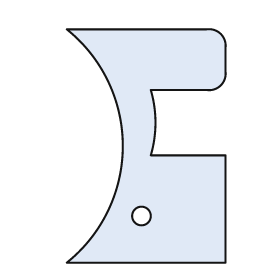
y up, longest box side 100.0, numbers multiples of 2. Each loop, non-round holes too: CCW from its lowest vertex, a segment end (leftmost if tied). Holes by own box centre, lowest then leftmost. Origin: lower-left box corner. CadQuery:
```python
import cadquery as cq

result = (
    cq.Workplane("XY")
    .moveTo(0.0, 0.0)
    .lineTo(68.0, 0.0)
    .lineTo(68.0, 46.0)
    .lineTo(36.0, 46.0)
    .threePointArc((38.0, 60.0), (36.0, 74.0))
    .lineTo(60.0, 74.0)
    .threePointArc((66.0, 76.0), (68.0, 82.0))
    .lineTo(68.0, 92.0)
    .threePointArc((66.0, 98.0), (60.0, 100.0))
    .lineTo(0.0, 100.0)
    .threePointArc((24.0, 50.0), (0.0, 0.0))
    .close()
    .moveTo(32.0, 20.0)
    .circle(4.0)
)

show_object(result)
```